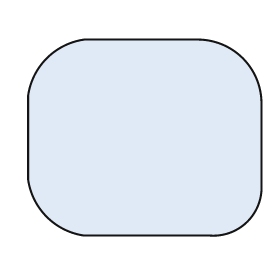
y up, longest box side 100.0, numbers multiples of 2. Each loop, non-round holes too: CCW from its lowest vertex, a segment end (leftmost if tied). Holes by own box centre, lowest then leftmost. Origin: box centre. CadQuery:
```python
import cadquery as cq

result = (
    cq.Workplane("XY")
    .moveTo(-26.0, -42.0)
    .lineTo(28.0, -42.0)
    .threePointArc((44.0, -36.0), (50.0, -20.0))
    .lineTo(50.0, 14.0)
    .threePointArc((42.0, 34.0), (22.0, 42.0))
    .lineTo(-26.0, 42.0)
    .threePointArc((-42.0, 34.0), (-50.0, 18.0))
    .lineTo(-50.0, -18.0)
    .threePointArc((-42.0, -34.0), (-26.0, -42.0))
    .close()
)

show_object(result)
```